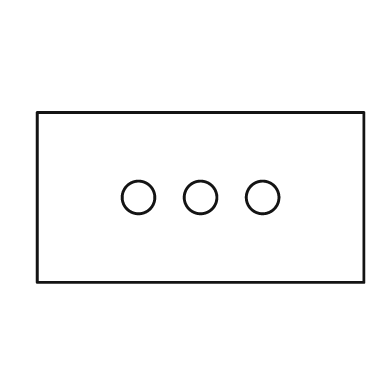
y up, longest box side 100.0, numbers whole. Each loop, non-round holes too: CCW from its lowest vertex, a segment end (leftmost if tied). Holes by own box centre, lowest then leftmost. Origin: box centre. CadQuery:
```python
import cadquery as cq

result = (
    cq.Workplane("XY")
    .moveTo(-50.0, -26.0)
    .lineTo(50.0, -26.0)
    .lineTo(50.0, 26.0)
    .lineTo(-50.0, 26.0)
    .close()
    .moveTo(-19.0, 0.0)
    .circle(5.0)
    .moveTo(0.0, 0.0)
    .circle(5.0)
    .moveTo(19.0, 0.0)
    .circle(5.0)
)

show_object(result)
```